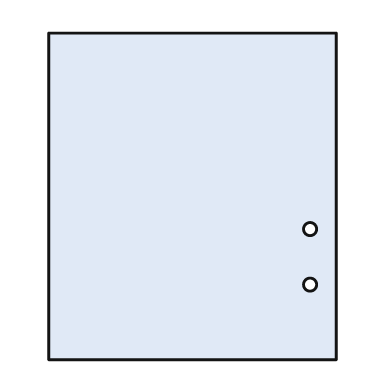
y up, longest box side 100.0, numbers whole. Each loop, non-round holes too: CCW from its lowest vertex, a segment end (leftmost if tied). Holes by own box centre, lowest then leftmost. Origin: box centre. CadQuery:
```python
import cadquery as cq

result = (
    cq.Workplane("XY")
    .moveTo(-44.0, -50.0)
    .lineTo(44.0, -50.0)
    .lineTo(44.0, 50.0)
    .lineTo(-44.0, 50.0)
    .close()
    .moveTo(36.0, -27.0)
    .circle(2.0)
    .moveTo(36.0, -10.0)
    .circle(2.0)
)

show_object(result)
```